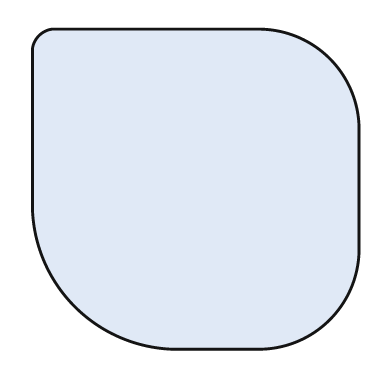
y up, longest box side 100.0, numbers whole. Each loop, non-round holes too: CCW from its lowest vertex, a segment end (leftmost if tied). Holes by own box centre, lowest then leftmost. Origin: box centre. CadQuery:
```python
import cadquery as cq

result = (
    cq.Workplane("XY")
    .moveTo(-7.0, -49.0)
    .lineTo(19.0, -49.0)
    .threePointArc((41.0, -40.0), (50.0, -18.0))
    .lineTo(50.0, 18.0)
    .threePointArc((41.0, 40.0), (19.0, 49.0))
    .lineTo(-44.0, 49.0)
    .threePointArc((-48.0, 47.0), (-50.0, 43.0))
    .lineTo(-50.0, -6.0)
    .threePointArc((-37.0, -36.0), (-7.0, -49.0))
    .close()
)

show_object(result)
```